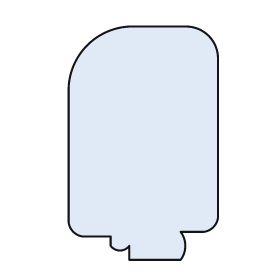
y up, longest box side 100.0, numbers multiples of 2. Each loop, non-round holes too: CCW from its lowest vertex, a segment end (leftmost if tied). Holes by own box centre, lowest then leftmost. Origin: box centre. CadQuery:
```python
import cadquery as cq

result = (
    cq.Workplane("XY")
    .moveTo(-6.0, -50.0)
    .lineTo(16.0, -50.0)
    .threePointArc((18.0, -44.0), (16.0, -38.0))
    .lineTo(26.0, -38.0)
    .threePointArc((30.0, -36.0), (32.0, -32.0))
    .lineTo(32.0, 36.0)
    .threePointArc((28.0, 46.0), (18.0, 50.0))
    .lineTo(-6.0, 50.0)
    .threePointArc((-24.0, 42.0), (-32.0, 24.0))
    .lineTo(-32.0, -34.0)
    .threePointArc((-30.0, -38.0), (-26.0, -40.0))
    .lineTo(-14.0, -40.0)
    .lineTo(-14.0, -44.0)
    .threePointArc((-10.0, -46.0), (-6.0, -44.0))
    .close()
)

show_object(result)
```